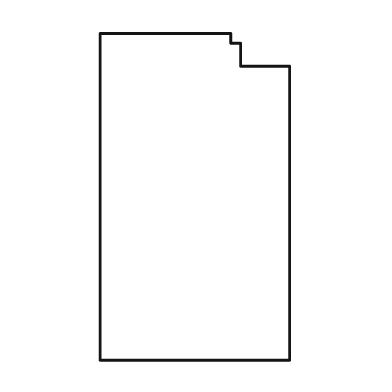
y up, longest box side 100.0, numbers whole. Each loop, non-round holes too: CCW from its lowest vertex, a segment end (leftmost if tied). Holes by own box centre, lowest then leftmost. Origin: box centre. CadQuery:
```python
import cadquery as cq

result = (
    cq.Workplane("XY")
    .moveTo(-29.0, -50.0)
    .lineTo(29.0, -50.0)
    .lineTo(29.0, 40.0)
    .lineTo(14.0, 40.0)
    .lineTo(14.0, 47.0)
    .lineTo(11.0, 47.0)
    .lineTo(11.0, 50.0)
    .lineTo(-29.0, 50.0)
    .close()
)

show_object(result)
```